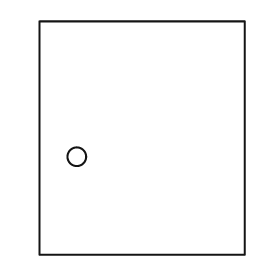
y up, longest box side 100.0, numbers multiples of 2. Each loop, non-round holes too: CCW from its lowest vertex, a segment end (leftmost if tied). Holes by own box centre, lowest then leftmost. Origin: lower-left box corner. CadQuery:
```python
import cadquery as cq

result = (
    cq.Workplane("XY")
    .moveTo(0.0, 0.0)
    .lineTo(88.0, 0.0)
    .lineTo(88.0, 100.0)
    .lineTo(0.0, 100.0)
    .close()
    .moveTo(16.0, 42.0)
    .circle(4.0)
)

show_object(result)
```